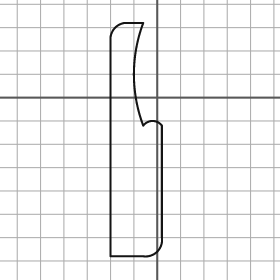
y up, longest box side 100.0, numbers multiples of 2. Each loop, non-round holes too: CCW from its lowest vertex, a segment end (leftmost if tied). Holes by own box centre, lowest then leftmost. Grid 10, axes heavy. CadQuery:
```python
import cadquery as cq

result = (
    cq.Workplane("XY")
    .moveTo(-20.0, -68.0)
    .lineTo(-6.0, -68.0)
    .threePointArc((0.0, -66.0), (2.0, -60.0))
    .lineTo(2.0, -12.0)
    .threePointArc((-2.0, -10.0), (-6.0, -12.0))
    .threePointArc((-10.0, 10.0), (-6.0, 32.0))
    .lineTo(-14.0, 32.0)
    .threePointArc((-18.0, 30.0), (-20.0, 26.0))
    .close()
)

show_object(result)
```